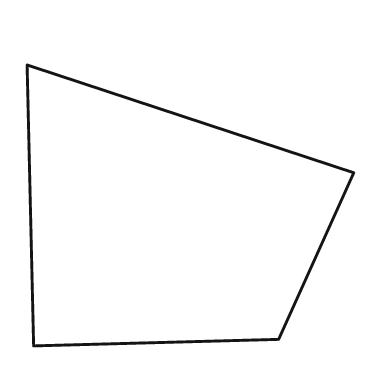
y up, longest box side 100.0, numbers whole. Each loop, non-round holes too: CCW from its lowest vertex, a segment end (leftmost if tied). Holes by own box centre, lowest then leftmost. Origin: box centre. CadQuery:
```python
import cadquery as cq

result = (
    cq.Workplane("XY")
    .moveTo(-48.0, -43.0)
    .lineTo(27.0, -41.0)
    .lineTo(50.0, 10.0)
    .lineTo(-50.0, 43.0)
    .close()
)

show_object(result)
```